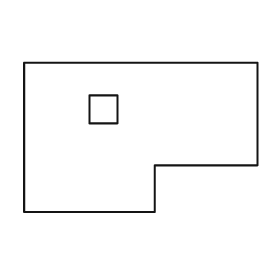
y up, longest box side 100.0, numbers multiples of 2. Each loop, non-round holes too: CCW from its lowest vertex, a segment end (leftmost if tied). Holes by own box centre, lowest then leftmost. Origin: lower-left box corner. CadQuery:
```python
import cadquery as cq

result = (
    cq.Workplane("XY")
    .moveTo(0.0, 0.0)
    .lineTo(56.0, 0.0)
    .lineTo(56.0, 20.0)
    .lineTo(100.0, 20.0)
    .lineTo(100.0, 64.0)
    .lineTo(0.0, 64.0)
    .close()
    .moveTo(28.0, 38.0)
    .lineTo(40.0, 38.0)
    .lineTo(40.0, 50.0)
    .lineTo(28.0, 50.0)
    .close()
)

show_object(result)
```